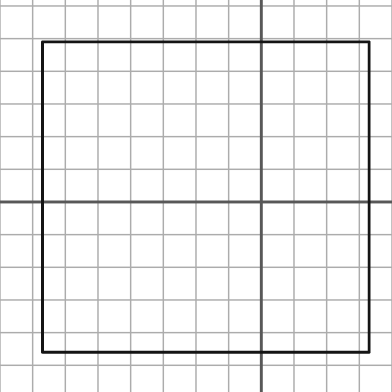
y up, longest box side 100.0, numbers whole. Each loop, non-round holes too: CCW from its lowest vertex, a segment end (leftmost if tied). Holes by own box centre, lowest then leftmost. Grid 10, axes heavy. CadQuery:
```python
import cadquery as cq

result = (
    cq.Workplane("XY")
    .moveTo(-67.0, -46.0)
    .lineTo(33.0, -46.0)
    .lineTo(33.0, 49.0)
    .lineTo(-67.0, 49.0)
    .close()
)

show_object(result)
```